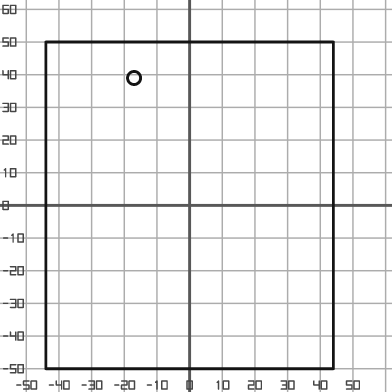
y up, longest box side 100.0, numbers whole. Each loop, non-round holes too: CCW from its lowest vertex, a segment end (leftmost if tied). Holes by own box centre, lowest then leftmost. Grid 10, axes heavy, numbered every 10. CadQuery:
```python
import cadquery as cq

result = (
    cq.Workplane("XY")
    .moveTo(-44.0, -50.0)
    .lineTo(44.0, -50.0)
    .lineTo(44.0, 50.0)
    .lineTo(-44.0, 50.0)
    .close()
    .moveTo(-17.0, 39.0)
    .circle(2.0)
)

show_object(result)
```